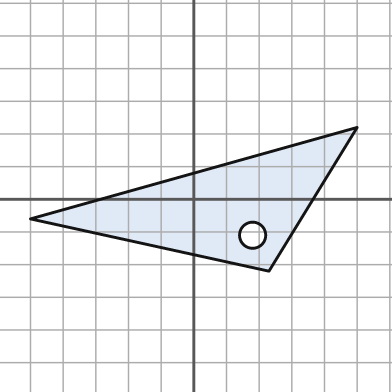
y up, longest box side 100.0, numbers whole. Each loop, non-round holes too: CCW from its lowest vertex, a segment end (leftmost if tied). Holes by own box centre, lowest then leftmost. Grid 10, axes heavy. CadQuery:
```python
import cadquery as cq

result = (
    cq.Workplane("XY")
    .moveTo(23.0, -22.0)
    .lineTo(50.0, 22.0)
    .lineTo(-50.0, -6.0)
    .close()
    .moveTo(18.0, -11.0)
    .circle(4.0)
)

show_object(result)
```